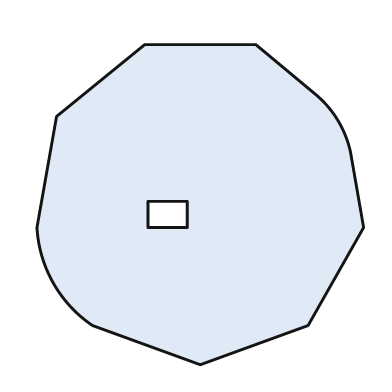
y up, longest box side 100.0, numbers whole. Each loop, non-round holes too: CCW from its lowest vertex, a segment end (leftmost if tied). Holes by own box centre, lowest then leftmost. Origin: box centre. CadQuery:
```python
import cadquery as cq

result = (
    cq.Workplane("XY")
    .moveTo(0.0, -49.0)
    .lineTo(33.0, -37.0)
    .lineTo(50.0, -7.0)
    .lineTo(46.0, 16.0)
    .threePointArc((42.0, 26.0), (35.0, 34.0))
    .lineTo(17.0, 49.0)
    .lineTo(-17.0, 49.0)
    .lineTo(-44.0, 27.0)
    .lineTo(-50.0, -7.0)
    .threePointArc((-45.0, -24.0), (-33.0, -37.0))
    .close()
    .moveTo(-16.0, -7.0)
    .lineTo(-4.0, -7.0)
    .lineTo(-4.0, 1.0)
    .lineTo(-16.0, 1.0)
    .close()
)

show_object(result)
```